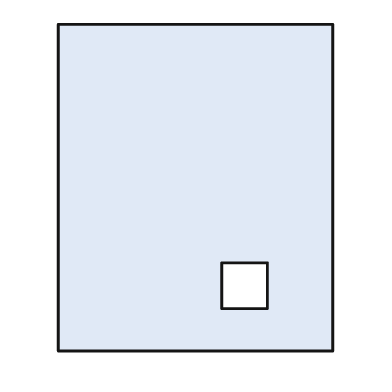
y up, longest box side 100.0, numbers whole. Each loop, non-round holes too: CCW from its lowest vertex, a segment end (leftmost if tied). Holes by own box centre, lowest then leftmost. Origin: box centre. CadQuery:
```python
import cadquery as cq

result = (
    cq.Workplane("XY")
    .moveTo(-42.0, -50.0)
    .lineTo(42.0, -50.0)
    .lineTo(42.0, 50.0)
    .lineTo(-42.0, 50.0)
    .close()
    .moveTo(8.0, -37.0)
    .lineTo(22.0, -37.0)
    .lineTo(22.0, -23.0)
    .lineTo(8.0, -23.0)
    .close()
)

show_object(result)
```